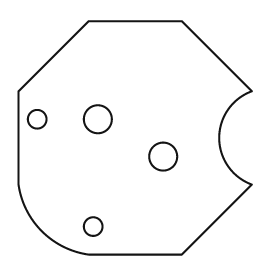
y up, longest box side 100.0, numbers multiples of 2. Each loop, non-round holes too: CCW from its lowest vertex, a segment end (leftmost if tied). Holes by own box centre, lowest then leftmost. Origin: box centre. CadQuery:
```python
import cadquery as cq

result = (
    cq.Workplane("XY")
    .moveTo(-20.0, -50.0)
    .lineTo(20.0, -50.0)
    .lineTo(50.0, -20.0)
    .threePointArc((36.0, 0.0), (50.0, 20.0))
    .lineTo(20.0, 50.0)
    .lineTo(-20.0, 50.0)
    .lineTo(-50.0, 20.0)
    .lineTo(-50.0, -20.0)
    .threePointArc((-40.0, -40.0), (-20.0, -50.0))
    .close()
    .moveTo(-18.0, -38.0)
    .circle(4.0)
    .moveTo(12.0, -8.0)
    .circle(6.0)
    .moveTo(-42.0, 8.0)
    .circle(4.0)
    .moveTo(-16.0, 8.0)
    .circle(6.0)
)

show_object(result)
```